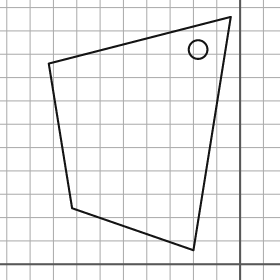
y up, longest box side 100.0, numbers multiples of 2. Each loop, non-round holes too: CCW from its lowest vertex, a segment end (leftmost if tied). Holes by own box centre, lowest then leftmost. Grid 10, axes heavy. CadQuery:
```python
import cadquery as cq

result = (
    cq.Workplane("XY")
    .moveTo(-20.0, 6.0)
    .lineTo(-4.0, 106.0)
    .lineTo(-82.0, 86.0)
    .lineTo(-72.0, 24.0)
    .close()
    .moveTo(-18.0, 92.0)
    .circle(4.0)
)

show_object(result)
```